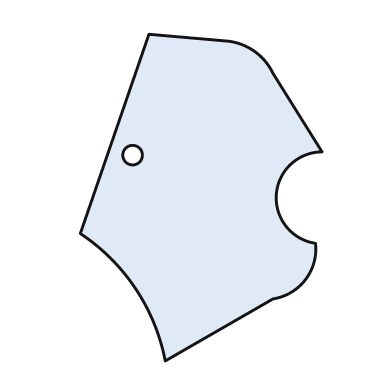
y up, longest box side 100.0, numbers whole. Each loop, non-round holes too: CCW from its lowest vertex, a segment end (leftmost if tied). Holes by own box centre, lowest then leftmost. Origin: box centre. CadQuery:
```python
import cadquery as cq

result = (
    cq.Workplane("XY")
    .moveTo(-11.0, -50.0)
    .lineTo(22.0, -31.0)
    .threePointArc((32.0, -25.0), (35.0, -14.0))
    .threePointArc((23.0, 1.0), (37.0, 14.0))
    .lineTo(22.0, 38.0)
    .threePointArc((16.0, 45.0), (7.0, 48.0))
    .lineTo(-16.0, 50.0)
    .lineTo(-37.0, -11.0)
    .threePointArc((-20.0, -28.0), (-11.0, -50.0))
    .close()
    .moveTo(-21.0, 13.0)
    .circle(3.0)
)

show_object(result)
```